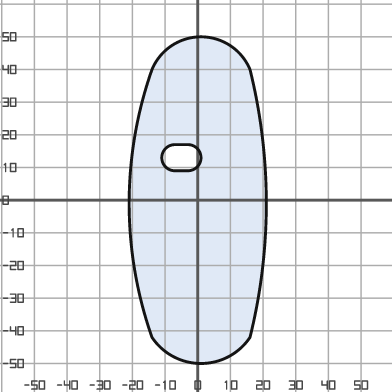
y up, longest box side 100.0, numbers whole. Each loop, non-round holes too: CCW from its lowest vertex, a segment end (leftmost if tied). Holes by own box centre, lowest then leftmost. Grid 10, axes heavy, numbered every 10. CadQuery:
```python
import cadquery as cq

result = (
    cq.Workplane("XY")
    .moveTo(-14.0, -42.0)
    .threePointArc((1.0, -50.0), (16.0, -42.0))
    .threePointArc((21.0, -1.0), (16.0, 40.0))
    .threePointArc((1.0, 50.0), (-14.0, 40.0))
    .threePointArc((-21.0, -1.0), (-14.0, -42.0))
    .close()
    .moveTo(-7.0, 9.0)
    .lineTo(-3.0, 9.0)
    .threePointArc((1.0, 13.0), (-3.0, 17.0))
    .lineTo(-7.0, 17.0)
    .threePointArc((-11.0, 13.0), (-7.0, 9.0))
    .close()
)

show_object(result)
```